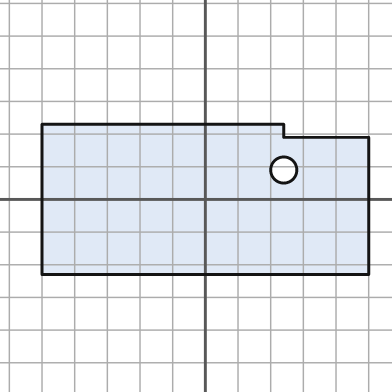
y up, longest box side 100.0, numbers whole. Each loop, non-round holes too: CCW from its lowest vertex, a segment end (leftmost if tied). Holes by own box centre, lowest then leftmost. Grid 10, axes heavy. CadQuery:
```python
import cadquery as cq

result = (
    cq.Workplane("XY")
    .moveTo(-50.0, -23.0)
    .lineTo(50.0, -23.0)
    .lineTo(50.0, 19.0)
    .lineTo(24.0, 19.0)
    .lineTo(24.0, 23.0)
    .lineTo(-50.0, 23.0)
    .close()
    .moveTo(24.0, 9.0)
    .circle(4.0)
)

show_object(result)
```